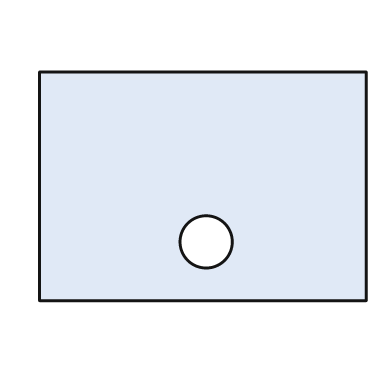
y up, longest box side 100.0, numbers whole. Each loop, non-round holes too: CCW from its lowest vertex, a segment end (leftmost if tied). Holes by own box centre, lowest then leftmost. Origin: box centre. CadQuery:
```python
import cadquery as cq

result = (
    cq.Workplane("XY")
    .moveTo(-50.0, -35.0)
    .lineTo(50.0, -35.0)
    .lineTo(50.0, 35.0)
    .lineTo(-50.0, 35.0)
    .close()
    .moveTo(1.0, -17.0)
    .circle(8.0)
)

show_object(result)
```